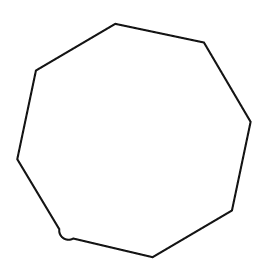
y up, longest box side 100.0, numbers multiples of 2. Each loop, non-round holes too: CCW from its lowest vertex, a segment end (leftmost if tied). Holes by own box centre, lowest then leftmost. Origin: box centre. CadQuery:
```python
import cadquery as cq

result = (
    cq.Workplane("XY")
    .moveTo(8.0, -50.0)
    .lineTo(42.0, -30.0)
    .lineTo(50.0, 8.0)
    .lineTo(30.0, 42.0)
    .lineTo(-8.0, 50.0)
    .lineTo(-42.0, 30.0)
    .lineTo(-50.0, -8.0)
    .lineTo(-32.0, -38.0)
    .threePointArc((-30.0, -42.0), (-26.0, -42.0))
    .close()
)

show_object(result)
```